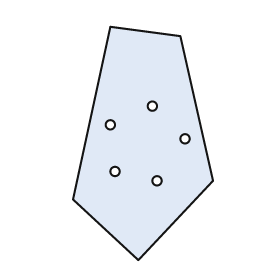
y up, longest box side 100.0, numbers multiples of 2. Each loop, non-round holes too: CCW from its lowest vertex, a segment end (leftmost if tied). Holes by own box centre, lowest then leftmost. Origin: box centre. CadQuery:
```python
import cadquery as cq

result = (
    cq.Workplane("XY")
    .moveTo(-2.0, -50.0)
    .lineTo(30.0, -16.0)
    .lineTo(16.0, 46.0)
    .lineTo(-14.0, 50.0)
    .lineTo(-30.0, -24.0)
    .close()
    .moveTo(6.0, -16.0)
    .circle(2.0)
    .moveTo(-12.0, -12.0)
    .circle(2.0)
    .moveTo(18.0, 2.0)
    .circle(2.0)
    .moveTo(-14.0, 8.0)
    .circle(2.0)
    .moveTo(4.0, 16.0)
    .circle(2.0)
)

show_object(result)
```